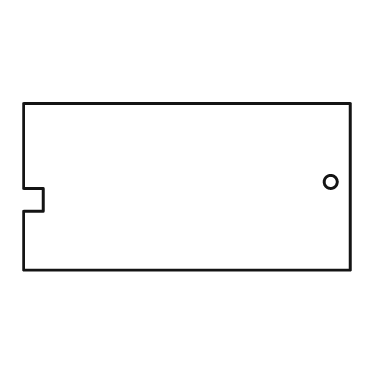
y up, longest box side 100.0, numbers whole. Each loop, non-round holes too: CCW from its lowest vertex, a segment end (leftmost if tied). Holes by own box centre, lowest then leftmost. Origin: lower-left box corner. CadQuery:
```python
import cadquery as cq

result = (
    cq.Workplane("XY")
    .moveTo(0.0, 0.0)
    .lineTo(100.0, 0.0)
    .lineTo(100.0, 51.0)
    .lineTo(0.0, 51.0)
    .lineTo(0.0, 25.0)
    .lineTo(6.0, 25.0)
    .lineTo(6.0, 18.0)
    .lineTo(0.0, 18.0)
    .close()
    .moveTo(94.0, 27.0)
    .circle(2.0)
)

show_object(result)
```